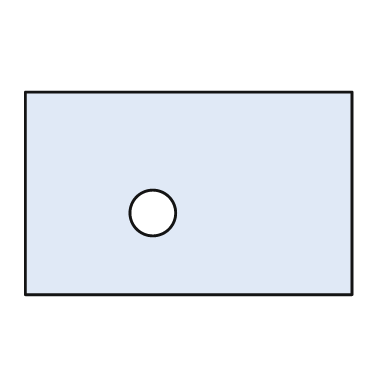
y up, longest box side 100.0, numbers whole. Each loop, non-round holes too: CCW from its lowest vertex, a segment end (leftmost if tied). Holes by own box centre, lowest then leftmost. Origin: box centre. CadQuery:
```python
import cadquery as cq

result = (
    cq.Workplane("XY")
    .moveTo(-50.0, -31.0)
    .lineTo(50.0, -31.0)
    .lineTo(50.0, 31.0)
    .lineTo(-50.0, 31.0)
    .close()
    .moveTo(-11.0, -6.0)
    .circle(7.0)
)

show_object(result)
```